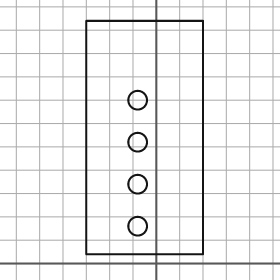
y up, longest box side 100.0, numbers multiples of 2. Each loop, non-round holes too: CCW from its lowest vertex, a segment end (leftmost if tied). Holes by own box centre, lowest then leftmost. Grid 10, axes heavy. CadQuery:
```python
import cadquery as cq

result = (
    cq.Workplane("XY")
    .moveTo(-30.0, 4.0)
    .lineTo(20.0, 4.0)
    .lineTo(20.0, 104.0)
    .lineTo(-30.0, 104.0)
    .close()
    .moveTo(-8.0, 16.0)
    .circle(4.0)
    .moveTo(-8.0, 34.0)
    .circle(4.0)
    .moveTo(-8.0, 52.0)
    .circle(4.0)
    .moveTo(-8.0, 70.0)
    .circle(4.0)
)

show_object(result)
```